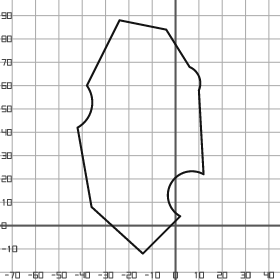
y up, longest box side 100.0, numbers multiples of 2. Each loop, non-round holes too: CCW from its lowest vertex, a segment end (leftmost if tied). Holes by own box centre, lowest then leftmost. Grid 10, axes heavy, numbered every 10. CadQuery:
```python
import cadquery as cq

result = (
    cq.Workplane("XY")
    .moveTo(-14.0, -12.0)
    .lineTo(2.0, 4.0)
    .threePointArc((-2.0, 18.0), (12.0, 22.0))
    .lineTo(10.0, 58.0)
    .threePointArc((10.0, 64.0), (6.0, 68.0))
    .lineTo(-4.0, 84.0)
    .lineTo(-24.0, 88.0)
    .lineTo(-38.0, 60.0)
    .threePointArc((-36.0, 50.0), (-42.0, 42.0))
    .lineTo(-36.0, 8.0)
    .close()
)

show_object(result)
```